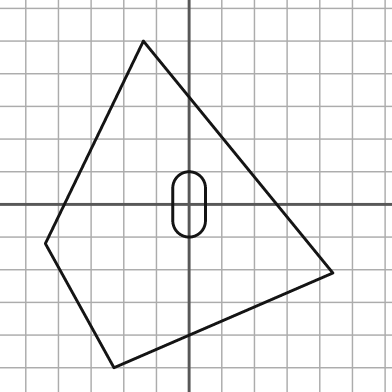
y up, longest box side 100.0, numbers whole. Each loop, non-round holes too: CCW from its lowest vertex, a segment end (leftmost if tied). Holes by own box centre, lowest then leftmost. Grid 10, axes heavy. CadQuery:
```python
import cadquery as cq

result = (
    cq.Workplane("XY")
    .moveTo(-23.0, -50.0)
    .lineTo(44.0, -21.0)
    .lineTo(-14.0, 50.0)
    .lineTo(-44.0, -12.0)
    .close()
    .moveTo(-5.0, -5.0)
    .threePointArc((0.0, -10.0), (5.0, -5.0))
    .lineTo(5.0, 5.0)
    .threePointArc((0.0, 10.0), (-5.0, 5.0))
    .close()
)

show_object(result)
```